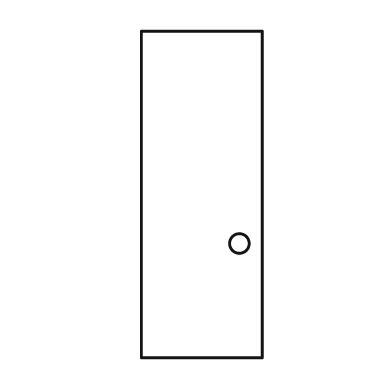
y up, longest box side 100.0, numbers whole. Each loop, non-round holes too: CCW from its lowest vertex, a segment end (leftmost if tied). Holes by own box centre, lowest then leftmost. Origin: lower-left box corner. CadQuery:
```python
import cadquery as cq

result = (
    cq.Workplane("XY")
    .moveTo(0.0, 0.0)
    .lineTo(37.0, 0.0)
    .lineTo(37.0, 100.0)
    .lineTo(0.0, 100.0)
    .close()
    .moveTo(30.0, 35.0)
    .circle(3.0)
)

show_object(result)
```